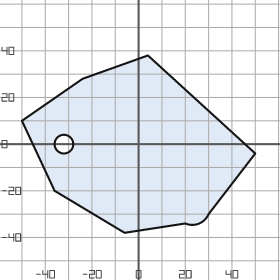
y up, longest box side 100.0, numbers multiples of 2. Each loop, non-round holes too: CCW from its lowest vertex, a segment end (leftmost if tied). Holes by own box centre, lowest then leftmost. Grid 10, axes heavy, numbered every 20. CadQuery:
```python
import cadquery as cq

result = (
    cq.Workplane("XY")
    .moveTo(-6.0, -38.0)
    .lineTo(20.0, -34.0)
    .threePointArc((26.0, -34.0), (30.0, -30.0))
    .lineTo(50.0, -4.0)
    .lineTo(4.0, 38.0)
    .lineTo(-24.0, 28.0)
    .lineTo(-50.0, 10.0)
    .lineTo(-36.0, -20.0)
    .close()
    .moveTo(-32.0, 0.0)
    .circle(4.0)
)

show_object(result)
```